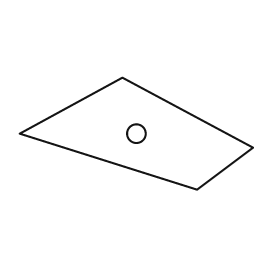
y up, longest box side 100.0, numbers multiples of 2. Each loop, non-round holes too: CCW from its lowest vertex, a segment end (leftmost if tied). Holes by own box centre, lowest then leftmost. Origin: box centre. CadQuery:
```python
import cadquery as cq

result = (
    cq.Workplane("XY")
    .moveTo(26.0, -24.0)
    .lineTo(50.0, -6.0)
    .lineTo(-6.0, 24.0)
    .lineTo(-50.0, 0.0)
    .close()
    .moveTo(0.0, 0.0)
    .circle(4.0)
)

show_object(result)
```